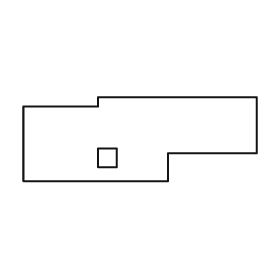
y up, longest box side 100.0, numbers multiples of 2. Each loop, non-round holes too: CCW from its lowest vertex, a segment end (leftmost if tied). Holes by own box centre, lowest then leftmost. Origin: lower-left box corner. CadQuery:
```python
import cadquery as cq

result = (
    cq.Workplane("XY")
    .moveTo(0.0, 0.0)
    .lineTo(62.0, 0.0)
    .lineTo(62.0, 12.0)
    .lineTo(100.0, 12.0)
    .lineTo(100.0, 36.0)
    .lineTo(32.0, 36.0)
    .lineTo(32.0, 32.0)
    .lineTo(0.0, 32.0)
    .close()
    .moveTo(32.0, 6.0)
    .lineTo(40.0, 6.0)
    .lineTo(40.0, 14.0)
    .lineTo(32.0, 14.0)
    .close()
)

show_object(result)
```